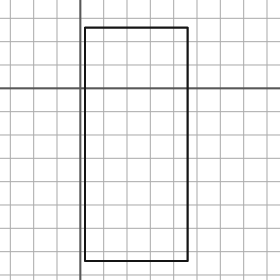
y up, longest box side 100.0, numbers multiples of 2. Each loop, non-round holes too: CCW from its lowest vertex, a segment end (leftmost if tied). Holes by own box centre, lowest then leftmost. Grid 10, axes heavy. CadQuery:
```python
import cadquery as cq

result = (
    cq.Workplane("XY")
    .moveTo(2.0, -74.0)
    .lineTo(46.0, -74.0)
    .lineTo(46.0, 26.0)
    .lineTo(2.0, 26.0)
    .close()
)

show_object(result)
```